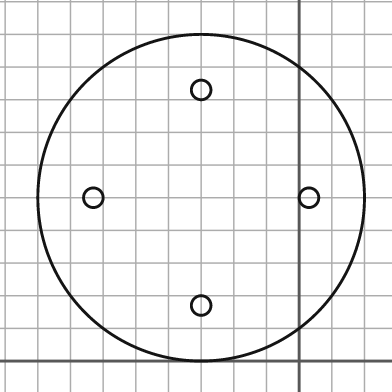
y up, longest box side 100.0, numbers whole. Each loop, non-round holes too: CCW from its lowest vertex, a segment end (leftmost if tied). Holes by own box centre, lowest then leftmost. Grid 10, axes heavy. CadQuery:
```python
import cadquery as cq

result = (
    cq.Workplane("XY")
    .moveTo(-30.0, 50.0)
    .circle(50.0)
    .moveTo(-30.0, 17.0)
    .circle(3.0)
    .moveTo(-63.0, 50.0)
    .circle(3.0)
    .moveTo(3.0, 50.0)
    .circle(3.0)
    .moveTo(-30.0, 83.0)
    .circle(3.0)
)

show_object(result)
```